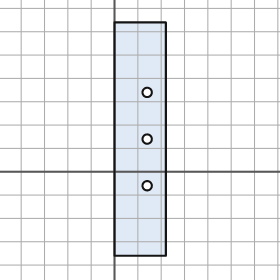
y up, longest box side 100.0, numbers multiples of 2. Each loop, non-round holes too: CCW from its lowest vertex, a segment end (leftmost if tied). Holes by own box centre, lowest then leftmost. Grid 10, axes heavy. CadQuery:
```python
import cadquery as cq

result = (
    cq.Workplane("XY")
    .moveTo(0.0, -36.0)
    .lineTo(22.0, -36.0)
    .lineTo(22.0, 64.0)
    .lineTo(0.0, 64.0)
    .close()
    .moveTo(14.0, -6.0)
    .circle(2.0)
    .moveTo(14.0, 14.0)
    .circle(2.0)
    .moveTo(14.0, 34.0)
    .circle(2.0)
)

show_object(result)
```